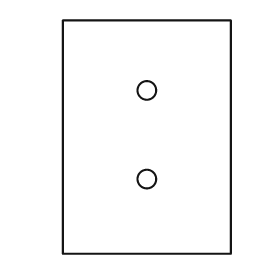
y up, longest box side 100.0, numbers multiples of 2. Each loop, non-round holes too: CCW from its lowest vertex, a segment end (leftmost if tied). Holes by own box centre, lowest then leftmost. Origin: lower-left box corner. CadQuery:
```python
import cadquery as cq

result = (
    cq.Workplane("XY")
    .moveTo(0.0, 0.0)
    .lineTo(72.0, 0.0)
    .lineTo(72.0, 100.0)
    .lineTo(0.0, 100.0)
    .close()
    .moveTo(36.0, 32.0)
    .circle(4.0)
    .moveTo(36.0, 70.0)
    .circle(4.0)
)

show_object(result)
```